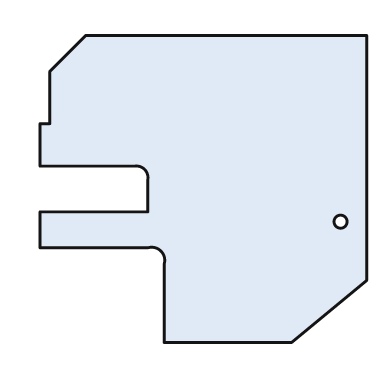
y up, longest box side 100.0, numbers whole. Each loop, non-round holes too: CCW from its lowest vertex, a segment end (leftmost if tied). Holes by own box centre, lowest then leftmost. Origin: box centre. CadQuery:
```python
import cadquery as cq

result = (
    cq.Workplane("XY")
    .moveTo(-12.0, -47.0)
    .lineTo(27.0, -47.0)
    .lineTo(50.0, -28.0)
    .lineTo(50.0, 47.0)
    .lineTo(-36.0, 47.0)
    .lineTo(-47.0, 36.0)
    .lineTo(-47.0, 20.0)
    .lineTo(-50.0, 20.0)
    .lineTo(-50.0, 7.0)
    .lineTo(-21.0, 7.0)
    .threePointArc((-18.0, 6.0), (-17.0, 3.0))
    .lineTo(-17.0, -7.0)
    .lineTo(-50.0, -7.0)
    .lineTo(-50.0, -18.0)
    .lineTo(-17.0, -18.0)
    .threePointArc((-13.0, -19.0), (-12.0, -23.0))
    .close()
    .moveTo(42.0, -10.0)
    .circle(2.0)
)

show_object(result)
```